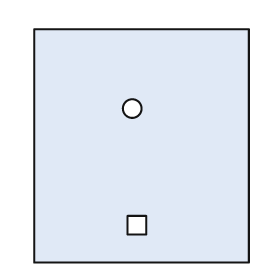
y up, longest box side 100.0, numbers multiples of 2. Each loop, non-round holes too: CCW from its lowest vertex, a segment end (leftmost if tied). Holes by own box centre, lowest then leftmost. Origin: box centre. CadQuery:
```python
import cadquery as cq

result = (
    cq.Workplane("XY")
    .moveTo(-46.0, -50.0)
    .lineTo(46.0, -50.0)
    .lineTo(46.0, 50.0)
    .lineTo(-46.0, 50.0)
    .close()
    .moveTo(-6.0, -38.0)
    .lineTo(2.0, -38.0)
    .lineTo(2.0, -30.0)
    .lineTo(-6.0, -30.0)
    .close()
    .moveTo(-4.0, 16.0)
    .circle(4.0)
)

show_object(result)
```